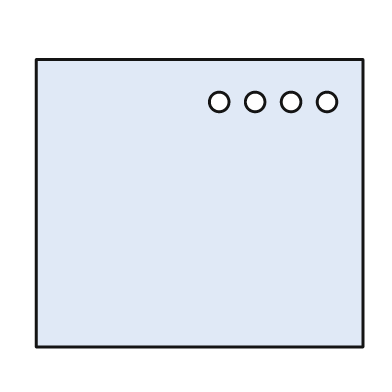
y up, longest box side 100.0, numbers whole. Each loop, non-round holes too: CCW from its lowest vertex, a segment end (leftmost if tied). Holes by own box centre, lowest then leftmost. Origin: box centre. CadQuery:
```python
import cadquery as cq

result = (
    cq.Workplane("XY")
    .moveTo(-50.0, -44.0)
    .lineTo(50.0, -44.0)
    .lineTo(50.0, 44.0)
    .lineTo(-50.0, 44.0)
    .close()
    .moveTo(6.0, 31.0)
    .circle(3.0)
    .moveTo(17.0, 31.0)
    .circle(3.0)
    .moveTo(28.0, 31.0)
    .circle(3.0)
    .moveTo(39.0, 31.0)
    .circle(3.0)
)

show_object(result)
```